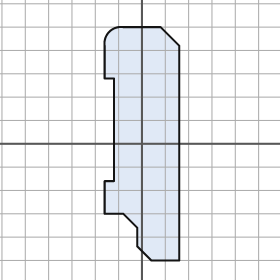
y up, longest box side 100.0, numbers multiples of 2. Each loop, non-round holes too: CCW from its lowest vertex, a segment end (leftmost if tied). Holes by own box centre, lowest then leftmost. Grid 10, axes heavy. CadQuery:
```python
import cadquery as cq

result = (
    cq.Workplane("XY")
    .moveTo(4.0, -50.0)
    .lineTo(16.0, -50.0)
    .lineTo(16.0, 42.0)
    .lineTo(8.0, 50.0)
    .lineTo(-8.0, 50.0)
    .threePointArc((-14.0, 48.0), (-16.0, 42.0))
    .lineTo(-16.0, 28.0)
    .lineTo(-12.0, 28.0)
    .lineTo(-12.0, -16.0)
    .lineTo(-16.0, -16.0)
    .lineTo(-16.0, -30.0)
    .lineTo(-8.0, -30.0)
    .lineTo(-2.0, -36.0)
    .lineTo(-2.0, -44.0)
    .close()
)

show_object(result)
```